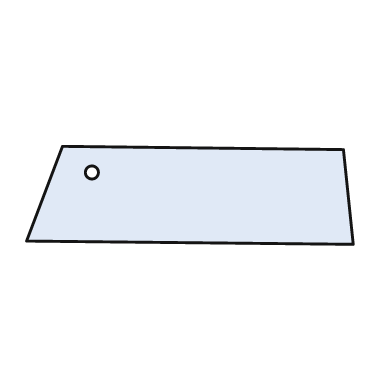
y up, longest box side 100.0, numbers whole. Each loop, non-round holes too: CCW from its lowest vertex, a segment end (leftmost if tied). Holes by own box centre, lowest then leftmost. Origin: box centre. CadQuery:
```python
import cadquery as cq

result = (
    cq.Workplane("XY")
    .moveTo(50.0, -15.0)
    .lineTo(47.0, 14.0)
    .lineTo(-39.0, 15.0)
    .lineTo(-50.0, -14.0)
    .close()
    .moveTo(-30.0, 7.0)
    .circle(2.0)
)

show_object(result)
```